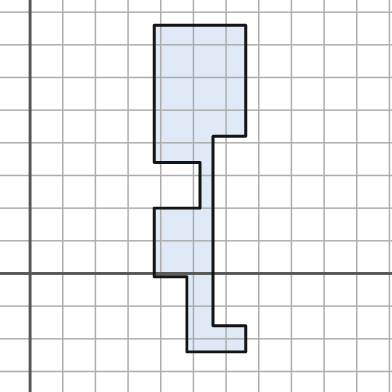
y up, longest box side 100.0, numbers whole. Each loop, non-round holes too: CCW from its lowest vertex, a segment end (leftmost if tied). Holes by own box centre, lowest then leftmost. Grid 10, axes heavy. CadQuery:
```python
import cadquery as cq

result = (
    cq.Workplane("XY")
    .moveTo(48.0, -24.0)
    .lineTo(66.0, -24.0)
    .lineTo(66.0, -16.0)
    .lineTo(56.0, -16.0)
    .lineTo(56.0, 42.0)
    .lineTo(66.0, 42.0)
    .lineTo(66.0, 76.0)
    .lineTo(38.0, 76.0)
    .lineTo(38.0, 34.0)
    .lineTo(52.0, 34.0)
    .lineTo(52.0, 20.0)
    .lineTo(38.0, 20.0)
    .lineTo(38.0, -1.0)
    .lineTo(48.0, -1.0)
    .close()
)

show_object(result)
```